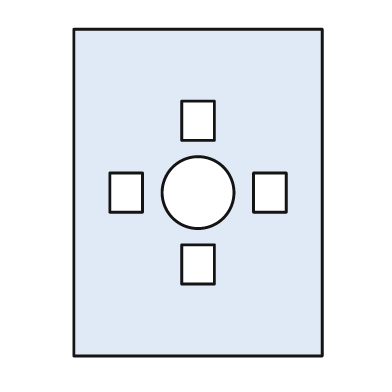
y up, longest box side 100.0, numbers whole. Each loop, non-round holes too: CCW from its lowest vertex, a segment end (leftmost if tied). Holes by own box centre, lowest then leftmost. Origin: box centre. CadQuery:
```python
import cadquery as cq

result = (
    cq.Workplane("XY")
    .moveTo(-38.0, -50.0)
    .lineTo(38.0, -50.0)
    .lineTo(38.0, 50.0)
    .lineTo(-38.0, 50.0)
    .close()
    .moveTo(-5.0, -28.0)
    .lineTo(5.0, -28.0)
    .lineTo(5.0, -16.0)
    .lineTo(-5.0, -16.0)
    .close()
    .moveTo(-27.0, -6.0)
    .lineTo(-17.0, -6.0)
    .lineTo(-17.0, 6.0)
    .lineTo(-27.0, 6.0)
    .close()
    .moveTo(0.0, 0.0)
    .circle(11.0)
    .moveTo(17.0, -6.0)
    .lineTo(27.0, -6.0)
    .lineTo(27.0, 6.0)
    .lineTo(17.0, 6.0)
    .close()
    .moveTo(-5.0, 16.0)
    .lineTo(5.0, 16.0)
    .lineTo(5.0, 28.0)
    .lineTo(-5.0, 28.0)
    .close()
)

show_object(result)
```